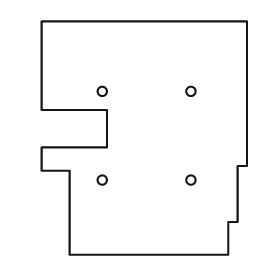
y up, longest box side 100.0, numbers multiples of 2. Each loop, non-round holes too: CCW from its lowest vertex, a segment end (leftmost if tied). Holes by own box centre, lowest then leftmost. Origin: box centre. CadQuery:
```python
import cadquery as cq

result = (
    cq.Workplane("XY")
    .moveTo(-32.0, -50.0)
    .lineTo(36.0, -50.0)
    .lineTo(36.0, -36.0)
    .lineTo(40.0, -36.0)
    .lineTo(40.0, -12.0)
    .lineTo(44.0, -12.0)
    .lineTo(44.0, 50.0)
    .lineTo(-44.0, 50.0)
    .lineTo(-44.0, 12.0)
    .lineTo(-16.0, 12.0)
    .lineTo(-16.0, -4.0)
    .lineTo(-44.0, -4.0)
    .lineTo(-44.0, -14.0)
    .lineTo(-32.0, -14.0)
    .close()
    .moveTo(-18.0, -18.0)
    .circle(2.0)
    .moveTo(20.0, -18.0)
    .circle(2.0)
    .moveTo(-18.0, 20.0)
    .circle(2.0)
    .moveTo(20.0, 20.0)
    .circle(2.0)
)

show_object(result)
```